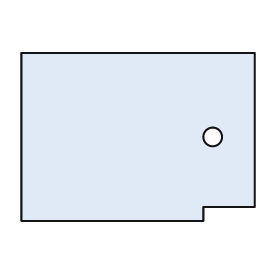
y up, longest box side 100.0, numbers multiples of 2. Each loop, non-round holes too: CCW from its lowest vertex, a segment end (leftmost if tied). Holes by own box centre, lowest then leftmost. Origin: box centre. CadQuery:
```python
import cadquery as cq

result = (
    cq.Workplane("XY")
    .moveTo(-50.0, -36.0)
    .lineTo(28.0, -36.0)
    .lineTo(28.0, -30.0)
    .lineTo(50.0, -30.0)
    .lineTo(50.0, 36.0)
    .lineTo(-50.0, 36.0)
    .close()
    .moveTo(32.0, 0.0)
    .circle(4.0)
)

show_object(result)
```